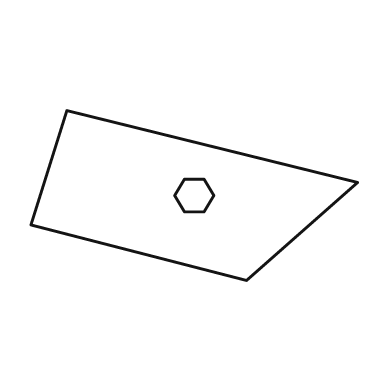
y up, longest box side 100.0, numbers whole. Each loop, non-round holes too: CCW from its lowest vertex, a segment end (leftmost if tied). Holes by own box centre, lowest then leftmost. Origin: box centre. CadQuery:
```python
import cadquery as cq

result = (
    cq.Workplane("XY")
    .moveTo(16.0, -26.0)
    .lineTo(50.0, 4.0)
    .lineTo(-39.0, 26.0)
    .lineTo(-50.0, -9.0)
    .close()
    .moveTo(-3.0, -5.0)
    .lineTo(3.0, -5.0)
    .lineTo(6.0, 0.0)
    .lineTo(3.0, 5.0)
    .lineTo(-3.0, 5.0)
    .lineTo(-6.0, 0.0)
    .close()
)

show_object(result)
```